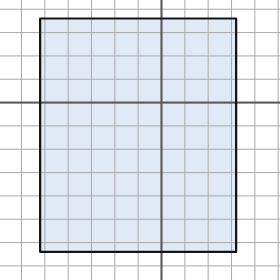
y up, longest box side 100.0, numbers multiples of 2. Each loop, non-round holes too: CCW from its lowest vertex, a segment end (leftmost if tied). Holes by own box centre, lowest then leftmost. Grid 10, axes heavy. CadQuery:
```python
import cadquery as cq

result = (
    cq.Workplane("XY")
    .moveTo(-52.0, -64.0)
    .lineTo(32.0, -64.0)
    .lineTo(32.0, 36.0)
    .lineTo(-52.0, 36.0)
    .close()
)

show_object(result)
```